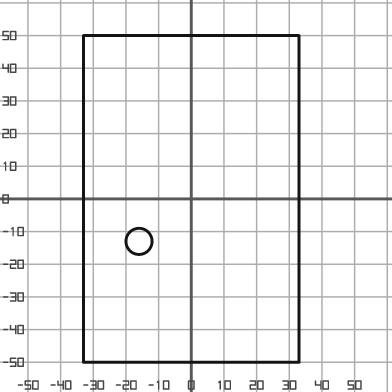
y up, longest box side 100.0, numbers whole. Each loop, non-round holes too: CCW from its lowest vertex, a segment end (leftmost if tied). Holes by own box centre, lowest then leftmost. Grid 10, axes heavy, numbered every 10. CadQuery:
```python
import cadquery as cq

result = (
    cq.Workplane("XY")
    .moveTo(-33.0, -50.0)
    .lineTo(33.0, -50.0)
    .lineTo(33.0, 50.0)
    .lineTo(-33.0, 50.0)
    .close()
    .moveTo(-16.0, -13.0)
    .circle(4.0)
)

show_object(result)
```